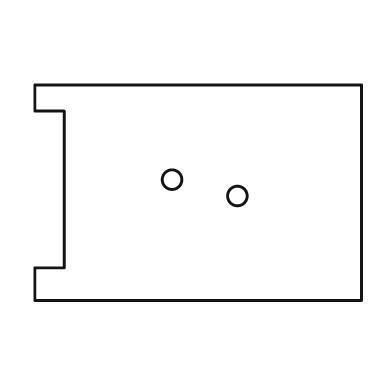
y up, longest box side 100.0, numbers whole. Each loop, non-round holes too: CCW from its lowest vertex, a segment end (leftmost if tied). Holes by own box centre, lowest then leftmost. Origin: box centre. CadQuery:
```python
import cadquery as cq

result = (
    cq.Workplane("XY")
    .moveTo(-50.0, -33.0)
    .lineTo(50.0, -33.0)
    .lineTo(50.0, 33.0)
    .lineTo(-50.0, 33.0)
    .lineTo(-50.0, 25.0)
    .lineTo(-41.0, 25.0)
    .lineTo(-41.0, -23.0)
    .lineTo(-50.0, -23.0)
    .close()
    .moveTo(12.0, -1.0)
    .circle(3.0)
    .moveTo(-8.0, 4.0)
    .circle(3.0)
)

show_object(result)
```